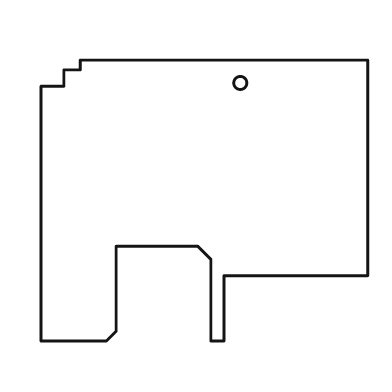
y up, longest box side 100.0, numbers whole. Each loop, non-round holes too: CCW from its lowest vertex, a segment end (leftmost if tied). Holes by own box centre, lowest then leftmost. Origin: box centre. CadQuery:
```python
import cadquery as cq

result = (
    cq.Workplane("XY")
    .moveTo(-50.0, -43.0)
    .lineTo(-30.0, -43.0)
    .lineTo(-27.0, -40.0)
    .lineTo(-27.0, -14.0)
    .lineTo(-2.0, -14.0)
    .lineTo(2.0, -18.0)
    .lineTo(2.0, -43.0)
    .lineTo(6.0, -43.0)
    .lineTo(6.0, -23.0)
    .lineTo(50.0, -23.0)
    .lineTo(50.0, 43.0)
    .lineTo(-38.0, 43.0)
    .lineTo(-38.0, 40.0)
    .lineTo(-43.0, 40.0)
    .lineTo(-43.0, 35.0)
    .lineTo(-50.0, 35.0)
    .close()
    .moveTo(11.0, 36.0)
    .circle(2.0)
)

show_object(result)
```